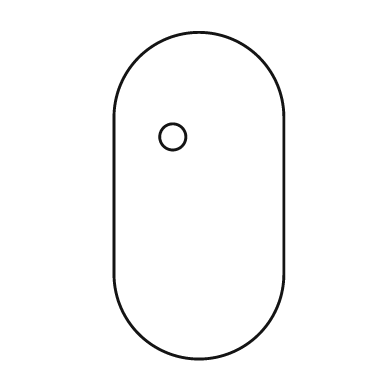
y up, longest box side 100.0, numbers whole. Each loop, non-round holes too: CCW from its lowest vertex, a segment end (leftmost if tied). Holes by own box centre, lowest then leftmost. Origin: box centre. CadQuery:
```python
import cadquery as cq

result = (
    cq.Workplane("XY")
    .moveTo(-26.0, -24.0)
    .threePointArc((0.0, -50.0), (26.0, -24.0))
    .lineTo(26.0, 24.0)
    .threePointArc((0.0, 50.0), (-26.0, 24.0))
    .close()
    .moveTo(-8.0, 18.0)
    .circle(4.0)
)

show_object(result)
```